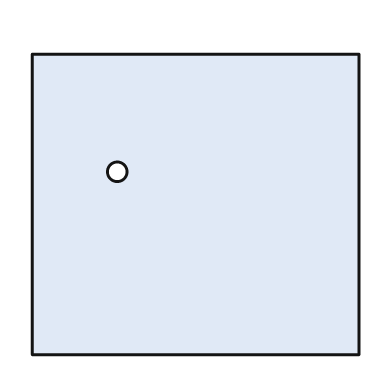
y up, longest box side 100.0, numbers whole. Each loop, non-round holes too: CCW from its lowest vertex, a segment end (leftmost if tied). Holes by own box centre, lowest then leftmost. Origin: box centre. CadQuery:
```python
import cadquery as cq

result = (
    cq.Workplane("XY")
    .moveTo(-50.0, -46.0)
    .lineTo(50.0, -46.0)
    .lineTo(50.0, 46.0)
    .lineTo(-50.0, 46.0)
    .close()
    .moveTo(-24.0, 10.0)
    .circle(3.0)
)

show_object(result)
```